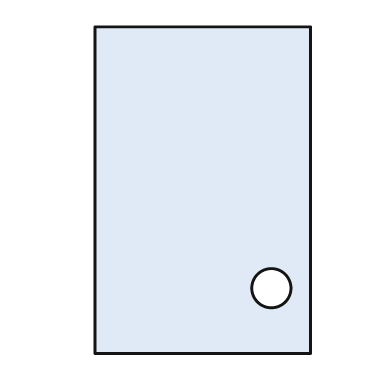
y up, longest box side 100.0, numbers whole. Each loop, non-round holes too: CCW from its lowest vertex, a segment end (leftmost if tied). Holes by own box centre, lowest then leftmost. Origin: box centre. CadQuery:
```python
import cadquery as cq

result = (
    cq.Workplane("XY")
    .moveTo(-33.0, -50.0)
    .lineTo(33.0, -50.0)
    .lineTo(33.0, 50.0)
    .lineTo(-33.0, 50.0)
    .close()
    .moveTo(21.0, -30.0)
    .circle(6.0)
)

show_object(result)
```